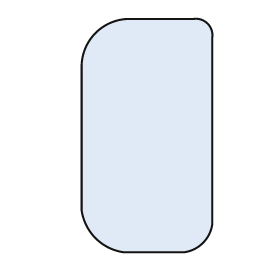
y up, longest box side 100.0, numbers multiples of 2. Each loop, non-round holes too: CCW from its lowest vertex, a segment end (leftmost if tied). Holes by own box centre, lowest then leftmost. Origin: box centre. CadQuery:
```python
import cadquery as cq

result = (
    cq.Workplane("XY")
    .moveTo(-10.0, -50.0)
    .lineTo(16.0, -50.0)
    .threePointArc((24.0, -46.0), (28.0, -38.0))
    .lineTo(28.0, 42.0)
    .threePointArc((26.0, 48.0), (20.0, 50.0))
    .lineTo(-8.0, 50.0)
    .threePointArc((-22.0, 44.0), (-28.0, 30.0))
    .lineTo(-28.0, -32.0)
    .threePointArc((-22.0, -44.0), (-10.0, -50.0))
    .close()
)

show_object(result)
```